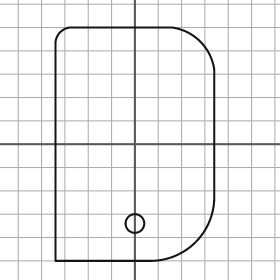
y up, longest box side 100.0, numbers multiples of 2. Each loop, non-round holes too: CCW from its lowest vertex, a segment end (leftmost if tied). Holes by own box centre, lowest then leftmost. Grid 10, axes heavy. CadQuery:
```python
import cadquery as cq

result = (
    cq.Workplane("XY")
    .moveTo(-34.0, -50.0)
    .lineTo(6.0, -50.0)
    .threePointArc((26.0, -42.0), (34.0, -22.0))
    .lineTo(34.0, 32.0)
    .threePointArc((28.0, 44.0), (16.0, 50.0))
    .lineTo(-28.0, 50.0)
    .threePointArc((-32.0, 48.0), (-34.0, 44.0))
    .close()
    .moveTo(0.0, -34.0)
    .circle(4.0)
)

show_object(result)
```